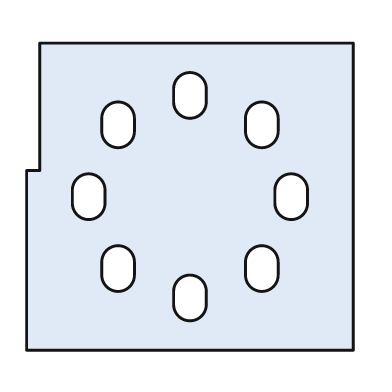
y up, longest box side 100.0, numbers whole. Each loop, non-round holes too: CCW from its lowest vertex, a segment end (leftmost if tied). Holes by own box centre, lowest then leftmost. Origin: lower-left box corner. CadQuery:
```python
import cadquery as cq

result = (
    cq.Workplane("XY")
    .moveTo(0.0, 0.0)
    .lineTo(100.0, 0.0)
    .lineTo(100.0, 94.0)
    .lineTo(4.0, 94.0)
    .lineTo(4.0, 55.0)
    .lineTo(0.0, 55.0)
    .close()
    .moveTo(45.0, 14.0)
    .threePointArc((50.0, 9.0), (55.0, 14.0))
    .lineTo(55.0, 18.0)
    .threePointArc((50.0, 23.0), (45.0, 18.0))
    .close()
    .moveTo(23.0, 23.0)
    .threePointArc((28.0, 18.0), (33.0, 23.0))
    .lineTo(33.0, 27.0)
    .threePointArc((28.0, 32.0), (23.0, 27.0))
    .close()
    .moveTo(67.0, 23.0)
    .threePointArc((72.0, 18.0), (77.0, 23.0))
    .lineTo(77.0, 27.0)
    .threePointArc((72.0, 32.0), (67.0, 27.0))
    .close()
    .moveTo(14.0, 45.0)
    .threePointArc((19.0, 40.0), (24.0, 45.0))
    .lineTo(24.0, 49.0)
    .threePointArc((19.0, 54.0), (14.0, 49.0))
    .close()
    .moveTo(76.0, 45.0)
    .threePointArc((81.0, 40.0), (86.0, 45.0))
    .lineTo(86.0, 49.0)
    .threePointArc((81.0, 54.0), (76.0, 49.0))
    .close()
    .moveTo(23.0, 67.0)
    .threePointArc((28.0, 62.0), (33.0, 67.0))
    .lineTo(33.0, 71.0)
    .threePointArc((28.0, 76.0), (23.0, 71.0))
    .close()
    .moveTo(67.0, 67.0)
    .threePointArc((72.0, 62.0), (77.0, 67.0))
    .lineTo(77.0, 71.0)
    .threePointArc((72.0, 76.0), (67.0, 71.0))
    .close()
    .moveTo(45.0, 76.0)
    .threePointArc((50.0, 71.0), (55.0, 76.0))
    .lineTo(55.0, 80.0)
    .threePointArc((50.0, 85.0), (45.0, 80.0))
    .close()
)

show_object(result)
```